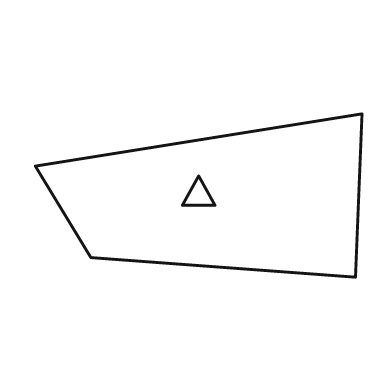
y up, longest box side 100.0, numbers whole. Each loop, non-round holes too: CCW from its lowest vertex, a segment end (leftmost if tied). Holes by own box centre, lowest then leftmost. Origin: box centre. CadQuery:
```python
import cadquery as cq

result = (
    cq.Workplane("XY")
    .moveTo(48.0, -25.0)
    .lineTo(50.0, 25.0)
    .lineTo(-50.0, 9.0)
    .lineTo(-33.0, -19.0)
    .close()
    .moveTo(-5.0, -3.0)
    .lineTo(5.0, -3.0)
    .lineTo(0.0, 6.0)
    .close()
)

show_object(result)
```